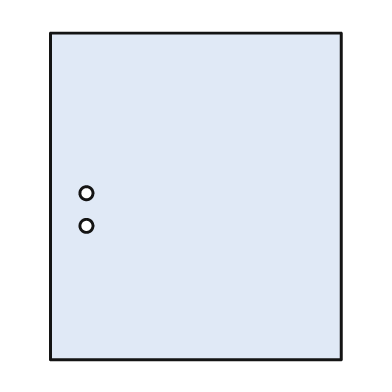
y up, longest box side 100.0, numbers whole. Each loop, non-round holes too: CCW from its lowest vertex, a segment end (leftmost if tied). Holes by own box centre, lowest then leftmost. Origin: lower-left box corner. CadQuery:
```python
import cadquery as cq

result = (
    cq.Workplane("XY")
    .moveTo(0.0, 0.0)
    .lineTo(89.0, 0.0)
    .lineTo(89.0, 100.0)
    .lineTo(0.0, 100.0)
    .close()
    .moveTo(11.0, 41.0)
    .circle(2.0)
    .moveTo(11.0, 51.0)
    .circle(2.0)
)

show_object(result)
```